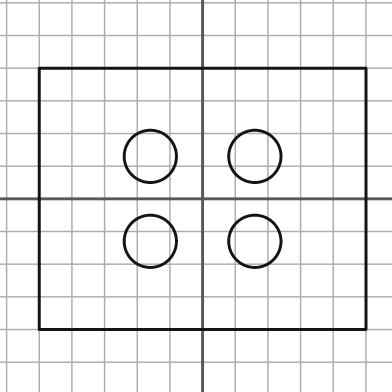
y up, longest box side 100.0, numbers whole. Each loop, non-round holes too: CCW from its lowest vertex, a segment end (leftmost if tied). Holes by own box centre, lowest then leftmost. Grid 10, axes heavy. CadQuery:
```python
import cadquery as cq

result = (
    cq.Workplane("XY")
    .moveTo(-50.0, -40.0)
    .lineTo(50.0, -40.0)
    .lineTo(50.0, 40.0)
    .lineTo(-50.0, 40.0)
    .close()
    .moveTo(-16.0, -13.0)
    .circle(8.0)
    .moveTo(16.0, -13.0)
    .circle(8.0)
    .moveTo(-16.0, 13.0)
    .circle(8.0)
    .moveTo(16.0, 13.0)
    .circle(8.0)
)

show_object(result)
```